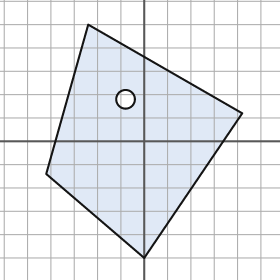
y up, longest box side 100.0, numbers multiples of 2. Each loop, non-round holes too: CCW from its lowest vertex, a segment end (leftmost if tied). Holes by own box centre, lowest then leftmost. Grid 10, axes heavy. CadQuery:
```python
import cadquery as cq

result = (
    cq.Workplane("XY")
    .moveTo(0.0, -50.0)
    .lineTo(42.0, 12.0)
    .lineTo(-24.0, 50.0)
    .lineTo(-42.0, -14.0)
    .close()
    .moveTo(-8.0, 18.0)
    .circle(4.0)
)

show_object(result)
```